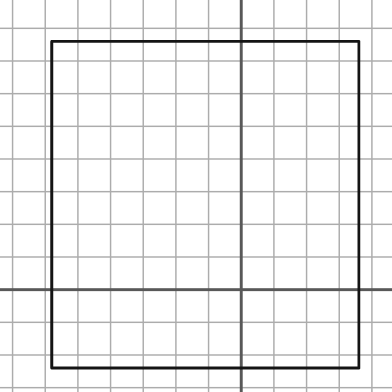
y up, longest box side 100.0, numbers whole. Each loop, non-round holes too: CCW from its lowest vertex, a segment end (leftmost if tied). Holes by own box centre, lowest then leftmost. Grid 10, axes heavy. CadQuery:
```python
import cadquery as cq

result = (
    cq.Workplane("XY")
    .moveTo(-58.0, -24.0)
    .lineTo(36.0, -24.0)
    .lineTo(36.0, 76.0)
    .lineTo(-58.0, 76.0)
    .close()
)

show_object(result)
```